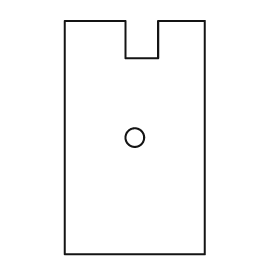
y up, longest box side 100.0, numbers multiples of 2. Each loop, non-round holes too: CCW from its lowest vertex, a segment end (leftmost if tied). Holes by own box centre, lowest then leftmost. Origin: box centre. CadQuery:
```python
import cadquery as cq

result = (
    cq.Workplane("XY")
    .moveTo(-30.0, -50.0)
    .lineTo(30.0, -50.0)
    .lineTo(30.0, 50.0)
    .lineTo(10.0, 50.0)
    .lineTo(10.0, 34.0)
    .lineTo(-4.0, 34.0)
    .lineTo(-4.0, 50.0)
    .lineTo(-30.0, 50.0)
    .close()
    .moveTo(0.0, 0.0)
    .circle(4.0)
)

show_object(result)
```